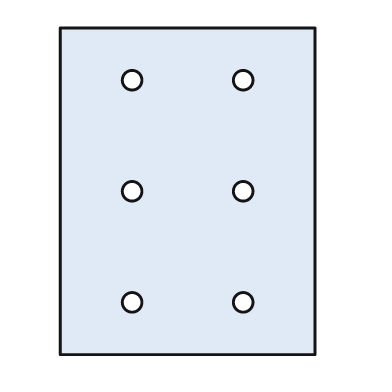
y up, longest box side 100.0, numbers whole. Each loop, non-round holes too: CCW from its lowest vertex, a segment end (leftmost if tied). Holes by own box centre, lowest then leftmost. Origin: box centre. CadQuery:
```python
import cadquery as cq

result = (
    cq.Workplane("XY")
    .moveTo(-39.0, -50.0)
    .lineTo(39.0, -50.0)
    .lineTo(39.0, 50.0)
    .lineTo(-39.0, 50.0)
    .close()
    .moveTo(-17.0, -34.0)
    .circle(3.0)
    .moveTo(17.0, -34.0)
    .circle(3.0)
    .moveTo(-17.0, 0.0)
    .circle(3.0)
    .moveTo(17.0, 0.0)
    .circle(3.0)
    .moveTo(-17.0, 34.0)
    .circle(3.0)
    .moveTo(17.0, 34.0)
    .circle(3.0)
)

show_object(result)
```